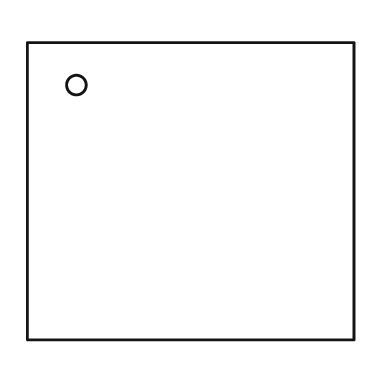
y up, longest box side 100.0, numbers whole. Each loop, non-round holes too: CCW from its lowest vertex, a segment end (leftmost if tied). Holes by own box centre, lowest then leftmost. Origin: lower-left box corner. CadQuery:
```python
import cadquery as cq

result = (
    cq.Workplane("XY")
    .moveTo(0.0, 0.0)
    .lineTo(100.0, 0.0)
    .lineTo(100.0, 91.0)
    .lineTo(0.0, 91.0)
    .close()
    .moveTo(15.0, 78.0)
    .circle(3.0)
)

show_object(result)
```